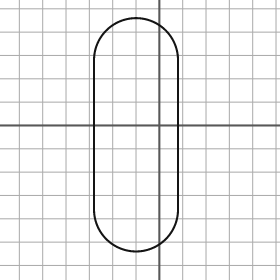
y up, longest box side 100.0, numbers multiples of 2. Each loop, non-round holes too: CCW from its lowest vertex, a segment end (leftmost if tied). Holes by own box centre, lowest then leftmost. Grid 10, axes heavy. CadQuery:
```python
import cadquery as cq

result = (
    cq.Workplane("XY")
    .moveTo(-28.0, -36.0)
    .threePointArc((-10.0, -54.0), (8.0, -36.0))
    .lineTo(8.0, 28.0)
    .threePointArc((-10.0, 46.0), (-28.0, 28.0))
    .close()
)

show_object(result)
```